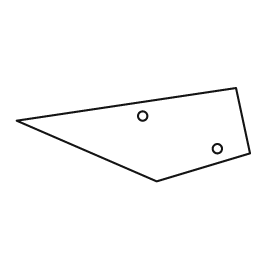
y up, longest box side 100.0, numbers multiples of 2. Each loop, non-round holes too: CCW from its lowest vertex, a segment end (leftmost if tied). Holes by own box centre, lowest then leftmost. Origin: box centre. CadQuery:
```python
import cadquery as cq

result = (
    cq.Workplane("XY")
    .moveTo(10.0, -20.0)
    .lineTo(50.0, -8.0)
    .lineTo(44.0, 20.0)
    .lineTo(-50.0, 6.0)
    .close()
    .moveTo(36.0, -6.0)
    .circle(2.0)
    .moveTo(4.0, 8.0)
    .circle(2.0)
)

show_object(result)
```